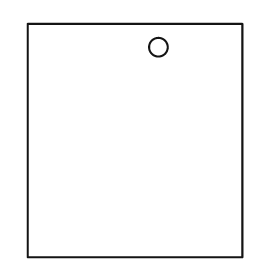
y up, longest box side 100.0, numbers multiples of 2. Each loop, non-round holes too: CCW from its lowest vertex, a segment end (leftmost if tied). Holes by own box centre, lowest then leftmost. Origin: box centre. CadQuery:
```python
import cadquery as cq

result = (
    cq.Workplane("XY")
    .moveTo(-46.0, -50.0)
    .lineTo(46.0, -50.0)
    .lineTo(46.0, 50.0)
    .lineTo(-46.0, 50.0)
    .close()
    .moveTo(10.0, 40.0)
    .circle(4.0)
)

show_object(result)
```